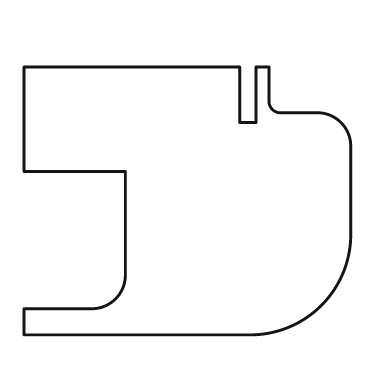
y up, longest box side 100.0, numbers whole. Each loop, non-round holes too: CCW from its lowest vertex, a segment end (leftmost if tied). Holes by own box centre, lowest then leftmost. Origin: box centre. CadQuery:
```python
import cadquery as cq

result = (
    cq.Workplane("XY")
    .moveTo(-50.0, -41.0)
    .lineTo(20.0, -41.0)
    .threePointArc((41.0, -32.0), (50.0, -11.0))
    .lineTo(50.0, 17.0)
    .threePointArc((47.0, 24.0), (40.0, 27.0))
    .lineTo(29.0, 27.0)
    .threePointArc((26.0, 28.0), (25.0, 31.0))
    .lineTo(25.0, 41.0)
    .lineTo(21.0, 41.0)
    .lineTo(21.0, 24.0)
    .lineTo(16.0, 24.0)
    .lineTo(16.0, 41.0)
    .lineTo(-50.0, 41.0)
    .lineTo(-50.0, 9.0)
    .lineTo(-19.0, 9.0)
    .lineTo(-19.0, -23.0)
    .threePointArc((-22.0, -30.0), (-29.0, -33.0))
    .lineTo(-50.0, -33.0)
    .close()
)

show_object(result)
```